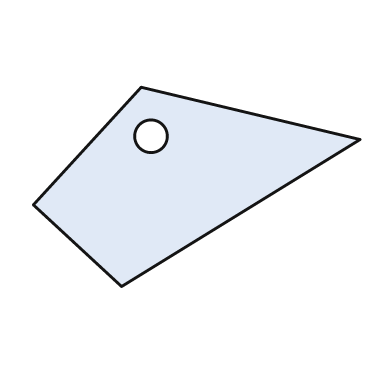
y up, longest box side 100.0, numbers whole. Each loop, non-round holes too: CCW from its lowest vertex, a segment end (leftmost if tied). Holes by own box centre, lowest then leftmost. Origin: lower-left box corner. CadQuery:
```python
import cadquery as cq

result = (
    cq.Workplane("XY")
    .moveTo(27.0, 0.0)
    .lineTo(100.0, 45.0)
    .lineTo(33.0, 61.0)
    .lineTo(0.0, 25.0)
    .close()
    .moveTo(36.0, 46.0)
    .circle(5.0)
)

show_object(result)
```